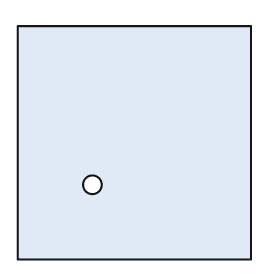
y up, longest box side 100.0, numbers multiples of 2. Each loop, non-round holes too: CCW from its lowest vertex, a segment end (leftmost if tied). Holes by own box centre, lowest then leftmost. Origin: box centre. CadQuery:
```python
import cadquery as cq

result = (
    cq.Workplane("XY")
    .moveTo(-50.0, -50.0)
    .lineTo(50.0, -50.0)
    .lineTo(50.0, 50.0)
    .lineTo(-50.0, 50.0)
    .close()
    .moveTo(-18.0, -18.0)
    .circle(4.0)
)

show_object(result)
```